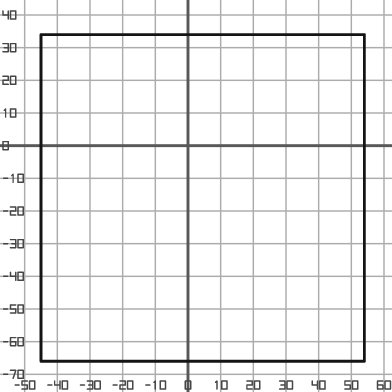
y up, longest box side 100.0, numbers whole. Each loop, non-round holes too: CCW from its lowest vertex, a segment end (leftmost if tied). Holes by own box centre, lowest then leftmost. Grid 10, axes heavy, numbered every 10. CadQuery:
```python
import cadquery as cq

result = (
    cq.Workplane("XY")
    .moveTo(-45.0, -66.0)
    .lineTo(54.0, -66.0)
    .lineTo(54.0, 34.0)
    .lineTo(-45.0, 34.0)
    .close()
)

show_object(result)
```